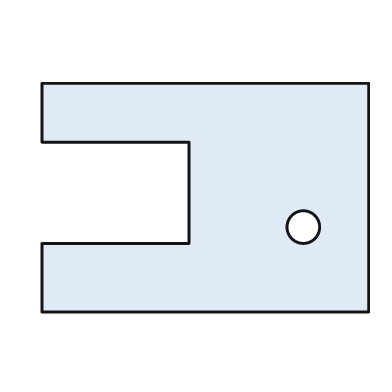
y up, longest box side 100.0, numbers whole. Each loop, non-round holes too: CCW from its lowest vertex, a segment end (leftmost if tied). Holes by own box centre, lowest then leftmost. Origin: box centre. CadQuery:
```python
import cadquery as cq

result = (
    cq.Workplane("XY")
    .moveTo(-50.0, -35.0)
    .lineTo(50.0, -35.0)
    .lineTo(50.0, 35.0)
    .lineTo(-50.0, 35.0)
    .lineTo(-50.0, 17.0)
    .lineTo(-5.0, 17.0)
    .lineTo(-5.0, -14.0)
    .lineTo(-50.0, -14.0)
    .close()
    .moveTo(30.0, -9.0)
    .circle(5.0)
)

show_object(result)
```